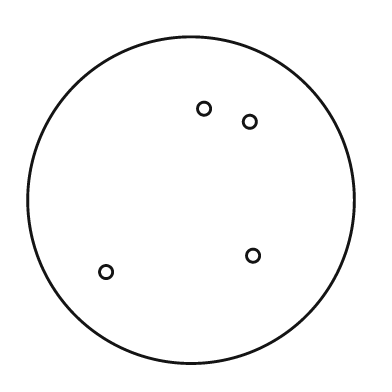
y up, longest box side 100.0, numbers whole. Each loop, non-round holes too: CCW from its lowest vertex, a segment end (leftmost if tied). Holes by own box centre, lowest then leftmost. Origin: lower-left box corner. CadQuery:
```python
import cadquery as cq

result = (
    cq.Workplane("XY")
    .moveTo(50.0, 50.0)
    .circle(50.0)
    .moveTo(24.0, 28.0)
    .circle(2.0)
    .moveTo(69.0, 33.0)
    .circle(2.0)
    .moveTo(68.0, 74.0)
    .circle(2.0)
    .moveTo(54.0, 78.0)
    .circle(2.0)
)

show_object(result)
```